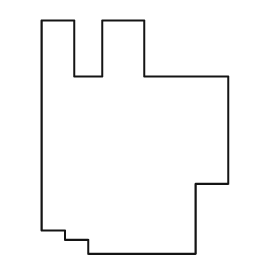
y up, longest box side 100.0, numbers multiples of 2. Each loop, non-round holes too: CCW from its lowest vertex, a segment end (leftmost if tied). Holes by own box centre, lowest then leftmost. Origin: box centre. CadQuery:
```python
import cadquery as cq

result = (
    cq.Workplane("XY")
    .moveTo(-20.0, -50.0)
    .lineTo(26.0, -50.0)
    .lineTo(26.0, -20.0)
    .lineTo(40.0, -20.0)
    .lineTo(40.0, 26.0)
    .lineTo(4.0, 26.0)
    .lineTo(4.0, 50.0)
    .lineTo(-14.0, 50.0)
    .lineTo(-14.0, 26.0)
    .lineTo(-26.0, 26.0)
    .lineTo(-26.0, 50.0)
    .lineTo(-40.0, 50.0)
    .lineTo(-40.0, -40.0)
    .lineTo(-30.0, -40.0)
    .lineTo(-30.0, -44.0)
    .lineTo(-20.0, -44.0)
    .close()
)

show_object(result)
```